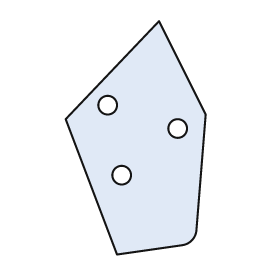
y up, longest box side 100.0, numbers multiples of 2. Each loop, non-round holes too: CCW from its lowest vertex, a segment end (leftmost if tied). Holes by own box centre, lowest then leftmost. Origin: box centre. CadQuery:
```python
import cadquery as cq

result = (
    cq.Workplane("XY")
    .moveTo(-8.0, -50.0)
    .lineTo(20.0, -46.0)
    .threePointArc((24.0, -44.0), (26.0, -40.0))
    .lineTo(30.0, 10.0)
    .lineTo(10.0, 50.0)
    .lineTo(-30.0, 8.0)
    .close()
    .moveTo(-6.0, -16.0)
    .circle(4.0)
    .moveTo(18.0, 4.0)
    .circle(4.0)
    .moveTo(-12.0, 14.0)
    .circle(4.0)
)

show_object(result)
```